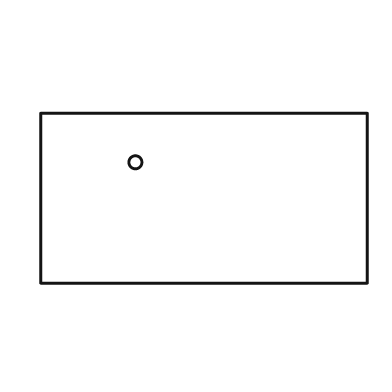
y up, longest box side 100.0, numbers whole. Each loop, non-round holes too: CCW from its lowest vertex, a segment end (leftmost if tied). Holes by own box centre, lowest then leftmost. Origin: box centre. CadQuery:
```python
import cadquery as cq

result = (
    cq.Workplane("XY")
    .moveTo(-50.0, -26.0)
    .lineTo(50.0, -26.0)
    .lineTo(50.0, 26.0)
    .lineTo(-50.0, 26.0)
    .close()
    .moveTo(-21.0, 11.0)
    .circle(2.0)
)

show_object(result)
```